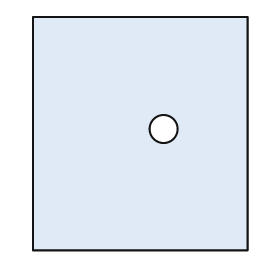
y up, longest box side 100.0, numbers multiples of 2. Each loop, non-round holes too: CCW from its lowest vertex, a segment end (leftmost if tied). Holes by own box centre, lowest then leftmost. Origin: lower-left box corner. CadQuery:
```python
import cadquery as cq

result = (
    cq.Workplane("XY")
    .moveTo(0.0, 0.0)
    .lineTo(92.0, 0.0)
    .lineTo(92.0, 100.0)
    .lineTo(0.0, 100.0)
    .close()
    .moveTo(56.0, 52.0)
    .circle(6.0)
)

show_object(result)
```